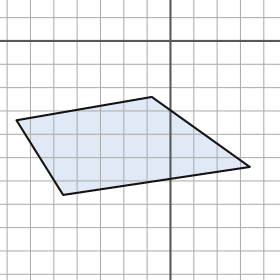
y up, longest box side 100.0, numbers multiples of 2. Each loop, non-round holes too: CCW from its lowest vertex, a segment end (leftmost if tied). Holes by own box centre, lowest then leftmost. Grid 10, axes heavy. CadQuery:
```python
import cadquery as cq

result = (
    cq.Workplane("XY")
    .moveTo(-46.0, -66.0)
    .lineTo(34.0, -54.0)
    .lineTo(-8.0, -24.0)
    .lineTo(-66.0, -34.0)
    .close()
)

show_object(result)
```